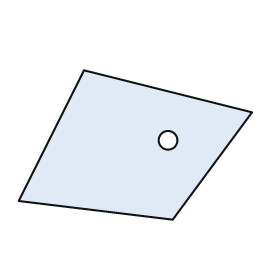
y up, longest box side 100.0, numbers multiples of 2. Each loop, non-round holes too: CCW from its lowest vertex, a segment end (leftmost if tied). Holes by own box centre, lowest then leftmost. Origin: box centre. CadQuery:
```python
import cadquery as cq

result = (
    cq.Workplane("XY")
    .moveTo(16.0, -32.0)
    .lineTo(50.0, 14.0)
    .lineTo(-22.0, 32.0)
    .lineTo(-50.0, -24.0)
    .close()
    .moveTo(14.0, 2.0)
    .circle(4.0)
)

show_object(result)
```